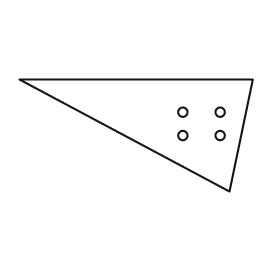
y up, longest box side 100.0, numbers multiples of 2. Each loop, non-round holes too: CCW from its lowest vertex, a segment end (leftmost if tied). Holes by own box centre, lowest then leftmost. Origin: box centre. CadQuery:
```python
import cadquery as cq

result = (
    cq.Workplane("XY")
    .moveTo(40.0, -24.0)
    .lineTo(50.0, 24.0)
    .lineTo(-50.0, 24.0)
    .close()
    .moveTo(20.0, 0.0)
    .circle(2.0)
    .moveTo(36.0, 0.0)
    .circle(2.0)
    .moveTo(20.0, 10.0)
    .circle(2.0)
    .moveTo(36.0, 10.0)
    .circle(2.0)
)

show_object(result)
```